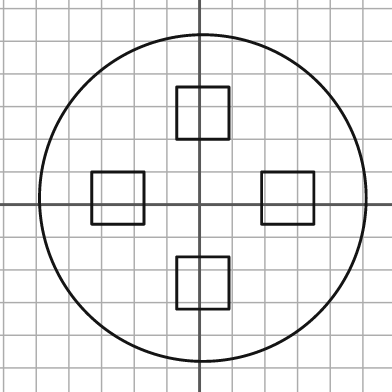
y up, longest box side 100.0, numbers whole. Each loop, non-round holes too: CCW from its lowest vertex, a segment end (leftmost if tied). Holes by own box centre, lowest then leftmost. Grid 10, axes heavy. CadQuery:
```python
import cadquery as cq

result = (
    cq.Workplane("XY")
    .moveTo(1.0, 2.0)
    .circle(50.0)
    .moveTo(-7.0, -32.0)
    .lineTo(9.0, -32.0)
    .lineTo(9.0, -16.0)
    .lineTo(-7.0, -16.0)
    .close()
    .moveTo(-33.0, -6.0)
    .lineTo(-17.0, -6.0)
    .lineTo(-17.0, 10.0)
    .lineTo(-33.0, 10.0)
    .close()
    .moveTo(19.0, -6.0)
    .lineTo(35.0, -6.0)
    .lineTo(35.0, 10.0)
    .lineTo(19.0, 10.0)
    .close()
    .moveTo(-7.0, 20.0)
    .lineTo(9.0, 20.0)
    .lineTo(9.0, 36.0)
    .lineTo(-7.0, 36.0)
    .close()
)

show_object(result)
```